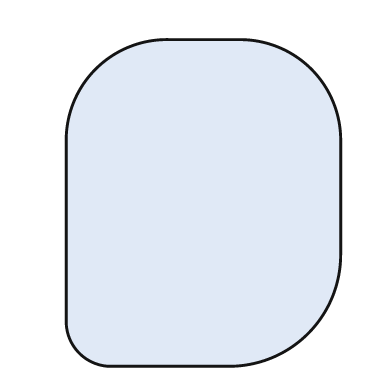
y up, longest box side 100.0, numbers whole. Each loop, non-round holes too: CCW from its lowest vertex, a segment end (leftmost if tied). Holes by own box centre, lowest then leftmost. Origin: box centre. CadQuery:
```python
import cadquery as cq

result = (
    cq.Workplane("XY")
    .moveTo(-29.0, -50.0)
    .lineTo(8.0, -50.0)
    .threePointArc((32.0, -40.0), (42.0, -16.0))
    .lineTo(42.0, 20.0)
    .threePointArc((33.0, 41.0), (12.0, 50.0))
    .lineTo(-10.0, 50.0)
    .threePointArc((-33.0, 41.0), (-42.0, 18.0))
    .lineTo(-42.0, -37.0)
    .threePointArc((-38.0, -46.0), (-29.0, -50.0))
    .close()
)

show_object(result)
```